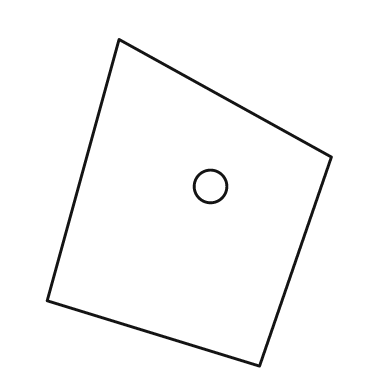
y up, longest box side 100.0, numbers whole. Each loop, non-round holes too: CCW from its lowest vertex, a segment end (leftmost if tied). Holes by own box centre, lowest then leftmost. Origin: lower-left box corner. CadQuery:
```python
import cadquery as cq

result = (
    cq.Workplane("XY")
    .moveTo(65.0, 0.0)
    .lineTo(87.0, 64.0)
    .lineTo(22.0, 100.0)
    .lineTo(0.0, 20.0)
    .close()
    .moveTo(50.0, 55.0)
    .circle(5.0)
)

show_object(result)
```